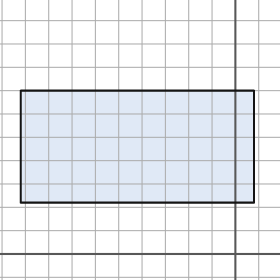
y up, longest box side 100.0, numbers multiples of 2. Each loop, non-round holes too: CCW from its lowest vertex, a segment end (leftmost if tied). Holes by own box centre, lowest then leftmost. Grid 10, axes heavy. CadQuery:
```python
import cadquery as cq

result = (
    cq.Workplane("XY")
    .moveTo(-92.0, 22.0)
    .lineTo(8.0, 22.0)
    .lineTo(8.0, 70.0)
    .lineTo(-92.0, 70.0)
    .close()
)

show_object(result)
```